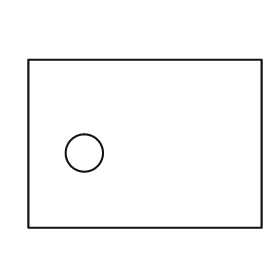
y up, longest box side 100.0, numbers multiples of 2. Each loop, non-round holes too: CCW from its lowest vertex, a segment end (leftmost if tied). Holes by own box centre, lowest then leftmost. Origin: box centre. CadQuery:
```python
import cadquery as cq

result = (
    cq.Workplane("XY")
    .moveTo(-50.0, -36.0)
    .lineTo(50.0, -36.0)
    .lineTo(50.0, 36.0)
    .lineTo(-50.0, 36.0)
    .close()
    .moveTo(-26.0, -4.0)
    .circle(8.0)
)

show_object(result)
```